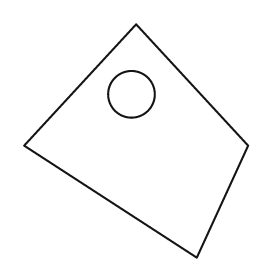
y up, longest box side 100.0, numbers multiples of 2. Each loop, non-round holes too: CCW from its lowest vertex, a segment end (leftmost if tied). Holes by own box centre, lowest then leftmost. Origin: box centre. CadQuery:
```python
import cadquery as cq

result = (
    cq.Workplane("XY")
    .moveTo(26.0, -50.0)
    .lineTo(48.0, -2.0)
    .lineTo(0.0, 50.0)
    .lineTo(-48.0, -2.0)
    .close()
    .moveTo(-2.0, 20.0)
    .circle(10.0)
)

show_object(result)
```